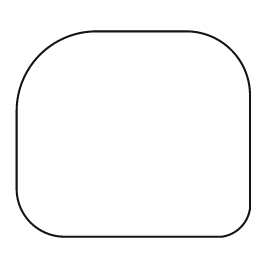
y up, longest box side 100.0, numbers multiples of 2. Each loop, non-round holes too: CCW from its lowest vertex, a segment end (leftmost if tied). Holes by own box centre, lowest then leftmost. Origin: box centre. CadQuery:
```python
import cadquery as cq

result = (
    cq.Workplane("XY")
    .moveTo(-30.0, -44.0)
    .lineTo(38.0, -44.0)
    .threePointArc((46.0, -40.0), (50.0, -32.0))
    .lineTo(50.0, 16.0)
    .threePointArc((42.0, 36.0), (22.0, 44.0))
    .lineTo(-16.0, 44.0)
    .threePointArc((-40.0, 34.0), (-50.0, 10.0))
    .lineTo(-50.0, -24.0)
    .threePointArc((-44.0, -38.0), (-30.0, -44.0))
    .close()
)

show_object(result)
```